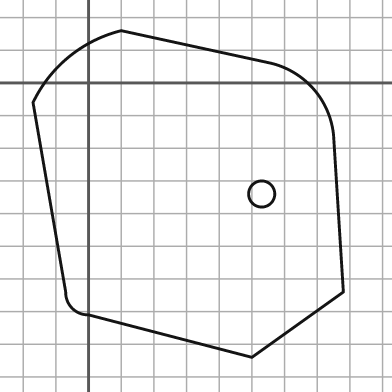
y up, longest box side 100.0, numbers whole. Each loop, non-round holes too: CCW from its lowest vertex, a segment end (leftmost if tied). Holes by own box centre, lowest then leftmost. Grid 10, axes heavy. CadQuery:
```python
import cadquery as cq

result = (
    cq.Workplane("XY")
    .moveTo(50.0, -84.0)
    .lineTo(78.0, -64.0)
    .lineTo(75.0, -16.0)
    .threePointArc((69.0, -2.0), (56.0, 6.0))
    .lineTo(10.0, 16.0)
    .threePointArc((-6.0, 8.0), (-17.0, -6.0))
    .lineTo(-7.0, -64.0)
    .threePointArc((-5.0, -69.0), (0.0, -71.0))
    .close()
    .moveTo(53.0, -34.0)
    .circle(4.0)
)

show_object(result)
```